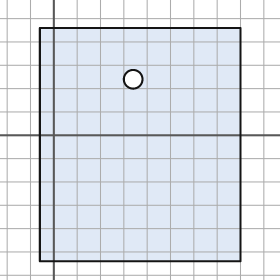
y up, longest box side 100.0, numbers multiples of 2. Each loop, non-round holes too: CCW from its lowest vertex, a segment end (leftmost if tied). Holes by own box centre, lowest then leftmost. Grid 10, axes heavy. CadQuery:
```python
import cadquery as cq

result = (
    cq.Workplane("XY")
    .moveTo(-6.0, -54.0)
    .lineTo(80.0, -54.0)
    .lineTo(80.0, 46.0)
    .lineTo(-6.0, 46.0)
    .close()
    .moveTo(34.0, 24.0)
    .circle(4.0)
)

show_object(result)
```